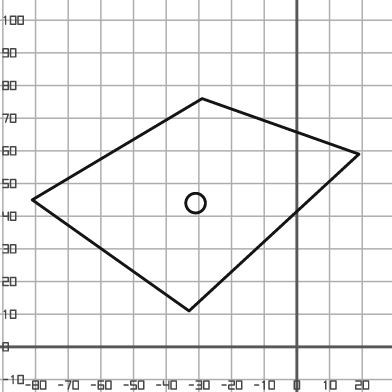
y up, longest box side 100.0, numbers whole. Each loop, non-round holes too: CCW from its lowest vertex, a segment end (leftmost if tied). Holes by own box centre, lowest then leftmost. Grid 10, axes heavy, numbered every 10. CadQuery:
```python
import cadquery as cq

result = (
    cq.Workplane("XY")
    .moveTo(-33.0, 11.0)
    .lineTo(19.0, 59.0)
    .lineTo(-29.0, 76.0)
    .lineTo(-81.0, 45.0)
    .close()
    .moveTo(-31.0, 44.0)
    .circle(3.0)
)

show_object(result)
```